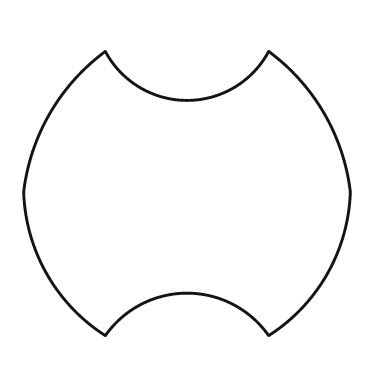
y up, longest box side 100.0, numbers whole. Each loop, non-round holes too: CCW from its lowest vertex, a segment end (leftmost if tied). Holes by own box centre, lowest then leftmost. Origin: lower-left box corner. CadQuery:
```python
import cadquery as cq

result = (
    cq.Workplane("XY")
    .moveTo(25.0, 0.0)
    .threePointArc((50.0, 13.0), (75.0, 0.0))
    .threePointArc((93.0, 19.0), (100.0, 44.0))
    .threePointArc((92.0, 68.0), (75.0, 87.0))
    .threePointArc((50.0, 72.0), (25.0, 87.0))
    .threePointArc((8.0, 68.0), (0.0, 44.0))
    .threePointArc((7.0, 19.0), (25.0, 0.0))
    .close()
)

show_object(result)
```